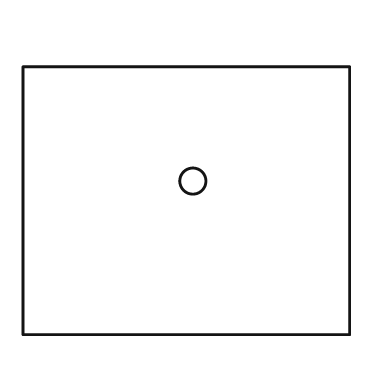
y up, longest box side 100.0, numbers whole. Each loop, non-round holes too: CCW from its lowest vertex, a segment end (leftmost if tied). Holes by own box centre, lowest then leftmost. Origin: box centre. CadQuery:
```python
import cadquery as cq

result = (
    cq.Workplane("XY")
    .moveTo(-50.0, -41.0)
    .lineTo(50.0, -41.0)
    .lineTo(50.0, 41.0)
    .lineTo(-50.0, 41.0)
    .close()
    .moveTo(2.0, 6.0)
    .circle(4.0)
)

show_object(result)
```